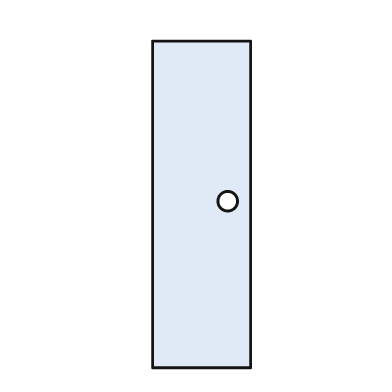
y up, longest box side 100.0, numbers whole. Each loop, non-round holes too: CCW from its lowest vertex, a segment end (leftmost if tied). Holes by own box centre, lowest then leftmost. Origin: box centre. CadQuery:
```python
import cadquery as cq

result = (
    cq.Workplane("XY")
    .moveTo(-15.0, -50.0)
    .lineTo(15.0, -50.0)
    .lineTo(15.0, 50.0)
    .lineTo(-15.0, 50.0)
    .close()
    .moveTo(8.0, 1.0)
    .circle(3.0)
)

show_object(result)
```